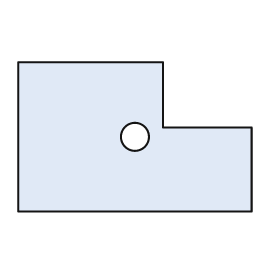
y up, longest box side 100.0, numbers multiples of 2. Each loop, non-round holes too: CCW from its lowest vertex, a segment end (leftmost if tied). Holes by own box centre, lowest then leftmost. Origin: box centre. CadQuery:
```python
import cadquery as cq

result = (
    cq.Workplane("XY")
    .moveTo(-50.0, -32.0)
    .lineTo(50.0, -32.0)
    .lineTo(50.0, 4.0)
    .lineTo(12.0, 4.0)
    .lineTo(12.0, 32.0)
    .lineTo(-50.0, 32.0)
    .close()
    .moveTo(0.0, 0.0)
    .circle(6.0)
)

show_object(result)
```